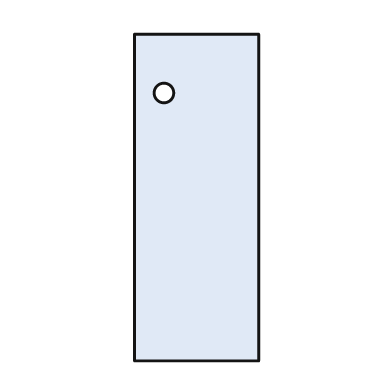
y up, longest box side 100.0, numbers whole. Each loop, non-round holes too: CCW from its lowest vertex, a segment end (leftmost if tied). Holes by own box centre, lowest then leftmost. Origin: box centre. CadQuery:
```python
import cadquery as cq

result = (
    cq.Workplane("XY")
    .moveTo(-19.0, -50.0)
    .lineTo(19.0, -50.0)
    .lineTo(19.0, 50.0)
    .lineTo(-19.0, 50.0)
    .close()
    .moveTo(-10.0, 32.0)
    .circle(3.0)
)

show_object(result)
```